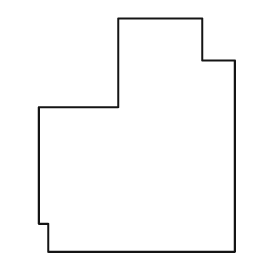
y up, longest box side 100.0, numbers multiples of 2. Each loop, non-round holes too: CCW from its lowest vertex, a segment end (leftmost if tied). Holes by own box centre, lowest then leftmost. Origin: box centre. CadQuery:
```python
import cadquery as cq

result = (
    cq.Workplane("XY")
    .moveTo(-38.0, -50.0)
    .lineTo(42.0, -50.0)
    .lineTo(42.0, 32.0)
    .lineTo(28.0, 32.0)
    .lineTo(28.0, 50.0)
    .lineTo(-8.0, 50.0)
    .lineTo(-8.0, 12.0)
    .lineTo(-42.0, 12.0)
    .lineTo(-42.0, -38.0)
    .lineTo(-38.0, -38.0)
    .close()
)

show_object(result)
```